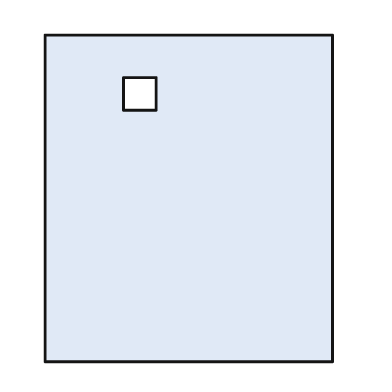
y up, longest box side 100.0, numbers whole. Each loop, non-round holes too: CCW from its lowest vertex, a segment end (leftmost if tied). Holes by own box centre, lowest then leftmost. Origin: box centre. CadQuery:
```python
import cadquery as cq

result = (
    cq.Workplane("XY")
    .moveTo(-44.0, -50.0)
    .lineTo(44.0, -50.0)
    .lineTo(44.0, 50.0)
    .lineTo(-44.0, 50.0)
    .close()
    .moveTo(-20.0, 27.0)
    .lineTo(-10.0, 27.0)
    .lineTo(-10.0, 37.0)
    .lineTo(-20.0, 37.0)
    .close()
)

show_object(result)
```